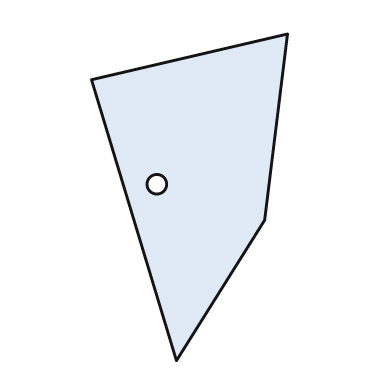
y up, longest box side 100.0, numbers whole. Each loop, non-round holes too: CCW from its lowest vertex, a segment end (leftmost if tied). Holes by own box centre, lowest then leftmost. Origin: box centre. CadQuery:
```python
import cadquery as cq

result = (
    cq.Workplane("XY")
    .moveTo(-4.0, -50.0)
    .lineTo(23.0, -7.0)
    .lineTo(30.0, 50.0)
    .lineTo(-30.0, 36.0)
    .close()
    .moveTo(-10.0, 4.0)
    .circle(3.0)
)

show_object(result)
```